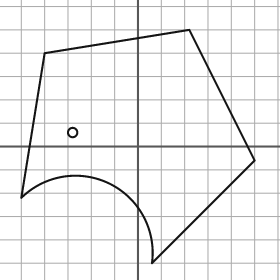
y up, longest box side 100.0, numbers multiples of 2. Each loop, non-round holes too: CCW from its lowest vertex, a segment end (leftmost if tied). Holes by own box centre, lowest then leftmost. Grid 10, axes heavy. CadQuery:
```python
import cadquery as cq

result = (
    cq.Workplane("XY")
    .moveTo(6.0, -50.0)
    .lineTo(50.0, -6.0)
    .lineTo(22.0, 50.0)
    .lineTo(-40.0, 40.0)
    .lineTo(-50.0, -22.0)
    .threePointArc((-12.0, -16.0), (6.0, -50.0))
    .close()
    .moveTo(-28.0, 6.0)
    .circle(2.0)
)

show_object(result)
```